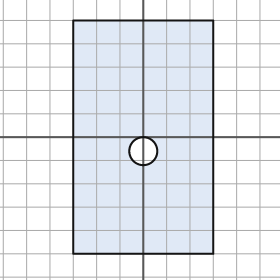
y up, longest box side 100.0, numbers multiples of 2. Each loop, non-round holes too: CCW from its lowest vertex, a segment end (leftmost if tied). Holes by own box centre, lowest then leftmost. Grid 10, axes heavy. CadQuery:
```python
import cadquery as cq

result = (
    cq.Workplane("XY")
    .moveTo(-30.0, -50.0)
    .lineTo(30.0, -50.0)
    .lineTo(30.0, 50.0)
    .lineTo(-30.0, 50.0)
    .close()
    .moveTo(0.0, -6.0)
    .circle(6.0)
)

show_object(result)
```